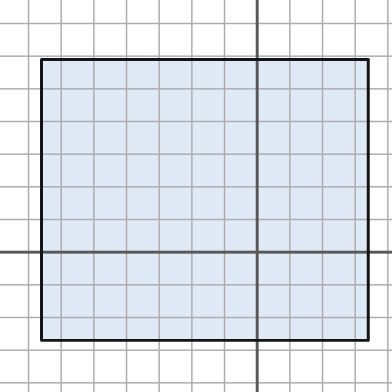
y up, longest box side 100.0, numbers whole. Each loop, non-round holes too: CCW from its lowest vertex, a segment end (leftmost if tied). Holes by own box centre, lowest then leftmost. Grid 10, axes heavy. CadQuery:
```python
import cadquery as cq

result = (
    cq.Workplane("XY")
    .moveTo(-66.0, -27.0)
    .lineTo(34.0, -27.0)
    .lineTo(34.0, 59.0)
    .lineTo(-66.0, 59.0)
    .close()
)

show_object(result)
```